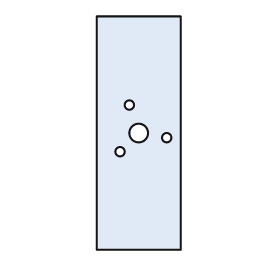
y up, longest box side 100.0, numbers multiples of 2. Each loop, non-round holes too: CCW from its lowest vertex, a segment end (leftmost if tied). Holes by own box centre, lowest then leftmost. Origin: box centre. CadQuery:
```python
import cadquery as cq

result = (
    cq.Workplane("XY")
    .moveTo(-18.0, -50.0)
    .lineTo(18.0, -50.0)
    .lineTo(18.0, 50.0)
    .lineTo(-18.0, 50.0)
    .close()
    .moveTo(-8.0, -8.0)
    .circle(2.0)
    .moveTo(12.0, -2.0)
    .circle(2.0)
    .moveTo(0.0, 0.0)
    .circle(4.0)
    .moveTo(-4.0, 12.0)
    .circle(2.0)
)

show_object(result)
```